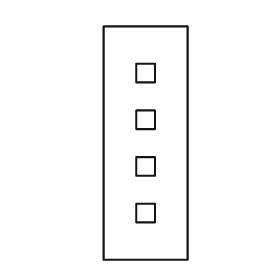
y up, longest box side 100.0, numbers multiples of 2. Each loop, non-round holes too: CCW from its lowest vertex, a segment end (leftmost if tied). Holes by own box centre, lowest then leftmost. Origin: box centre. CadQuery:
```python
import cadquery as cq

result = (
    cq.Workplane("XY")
    .moveTo(-18.0, -50.0)
    .lineTo(18.0, -50.0)
    .lineTo(18.0, 50.0)
    .lineTo(-18.0, 50.0)
    .close()
    .moveTo(-4.0, -34.0)
    .lineTo(4.0, -34.0)
    .lineTo(4.0, -26.0)
    .lineTo(-4.0, -26.0)
    .close()
    .moveTo(-4.0, -14.0)
    .lineTo(4.0, -14.0)
    .lineTo(4.0, -6.0)
    .lineTo(-4.0, -6.0)
    .close()
    .moveTo(-4.0, 6.0)
    .lineTo(4.0, 6.0)
    .lineTo(4.0, 14.0)
    .lineTo(-4.0, 14.0)
    .close()
    .moveTo(-4.0, 26.0)
    .lineTo(4.0, 26.0)
    .lineTo(4.0, 34.0)
    .lineTo(-4.0, 34.0)
    .close()
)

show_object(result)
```